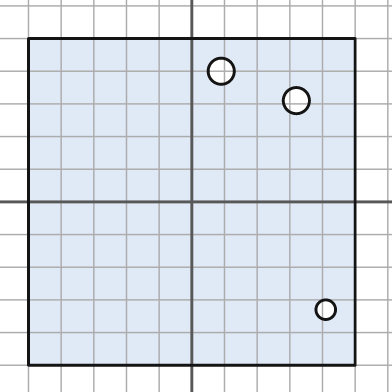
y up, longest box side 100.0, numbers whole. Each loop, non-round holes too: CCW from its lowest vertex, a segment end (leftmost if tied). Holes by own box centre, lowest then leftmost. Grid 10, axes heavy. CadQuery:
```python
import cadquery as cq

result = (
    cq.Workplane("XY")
    .moveTo(-50.0, -50.0)
    .lineTo(50.0, -50.0)
    .lineTo(50.0, 50.0)
    .lineTo(-50.0, 50.0)
    .close()
    .moveTo(41.0, -33.0)
    .circle(3.0)
    .moveTo(32.0, 31.0)
    .circle(4.0)
    .moveTo(9.0, 40.0)
    .circle(4.0)
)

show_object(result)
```